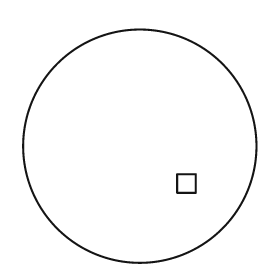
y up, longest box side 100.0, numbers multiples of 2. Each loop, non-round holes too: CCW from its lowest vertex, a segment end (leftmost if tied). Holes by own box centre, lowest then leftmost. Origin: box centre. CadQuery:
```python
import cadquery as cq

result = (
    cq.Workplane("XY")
    .moveTo(0.0, 0.0)
    .circle(50.0)
    .moveTo(16.0, -20.0)
    .lineTo(24.0, -20.0)
    .lineTo(24.0, -12.0)
    .lineTo(16.0, -12.0)
    .close()
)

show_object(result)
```